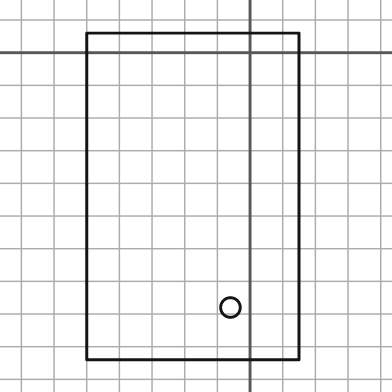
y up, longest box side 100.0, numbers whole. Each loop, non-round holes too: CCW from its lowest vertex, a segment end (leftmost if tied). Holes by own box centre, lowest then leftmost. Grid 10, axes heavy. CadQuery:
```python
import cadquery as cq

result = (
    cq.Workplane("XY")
    .moveTo(-50.0, -94.0)
    .lineTo(15.0, -94.0)
    .lineTo(15.0, 6.0)
    .lineTo(-50.0, 6.0)
    .close()
    .moveTo(-6.0, -78.0)
    .circle(3.0)
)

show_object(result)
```